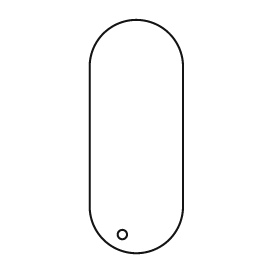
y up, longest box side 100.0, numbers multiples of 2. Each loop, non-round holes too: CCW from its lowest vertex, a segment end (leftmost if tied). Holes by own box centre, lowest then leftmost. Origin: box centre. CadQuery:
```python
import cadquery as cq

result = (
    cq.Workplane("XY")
    .moveTo(-20.0, -30.0)
    .threePointArc((0.0, -50.0), (20.0, -30.0))
    .lineTo(20.0, 30.0)
    .threePointArc((0.0, 50.0), (-20.0, 30.0))
    .close()
    .moveTo(-6.0, -42.0)
    .circle(2.0)
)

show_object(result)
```